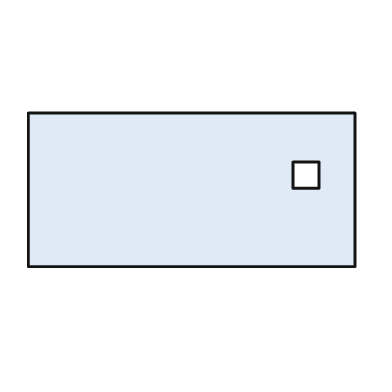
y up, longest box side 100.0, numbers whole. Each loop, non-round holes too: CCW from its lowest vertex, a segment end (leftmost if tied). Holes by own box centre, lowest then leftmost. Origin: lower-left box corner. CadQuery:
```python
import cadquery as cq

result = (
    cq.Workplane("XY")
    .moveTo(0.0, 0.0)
    .lineTo(100.0, 0.0)
    .lineTo(100.0, 47.0)
    .lineTo(0.0, 47.0)
    .close()
    .moveTo(81.0, 24.0)
    .lineTo(89.0, 24.0)
    .lineTo(89.0, 32.0)
    .lineTo(81.0, 32.0)
    .close()
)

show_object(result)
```